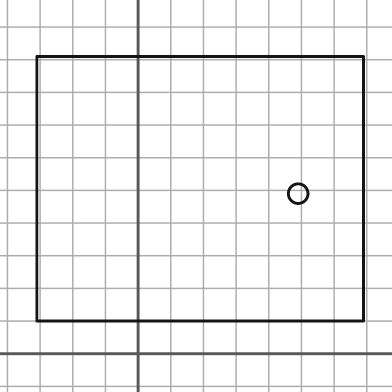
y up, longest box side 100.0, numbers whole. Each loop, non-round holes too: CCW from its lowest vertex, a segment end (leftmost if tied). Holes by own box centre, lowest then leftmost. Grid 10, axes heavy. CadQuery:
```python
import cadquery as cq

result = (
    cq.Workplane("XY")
    .moveTo(-31.0, 10.0)
    .lineTo(69.0, 10.0)
    .lineTo(69.0, 91.0)
    .lineTo(-31.0, 91.0)
    .close()
    .moveTo(49.0, 49.0)
    .circle(3.0)
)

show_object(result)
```